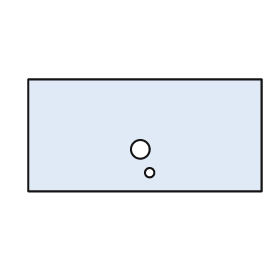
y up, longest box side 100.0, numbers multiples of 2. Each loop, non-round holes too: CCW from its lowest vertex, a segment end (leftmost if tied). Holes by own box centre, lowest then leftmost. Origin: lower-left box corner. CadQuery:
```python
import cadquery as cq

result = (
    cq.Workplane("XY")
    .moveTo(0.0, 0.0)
    .lineTo(100.0, 0.0)
    .lineTo(100.0, 48.0)
    .lineTo(0.0, 48.0)
    .close()
    .moveTo(52.0, 8.0)
    .circle(2.0)
    .moveTo(48.0, 18.0)
    .circle(4.0)
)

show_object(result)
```